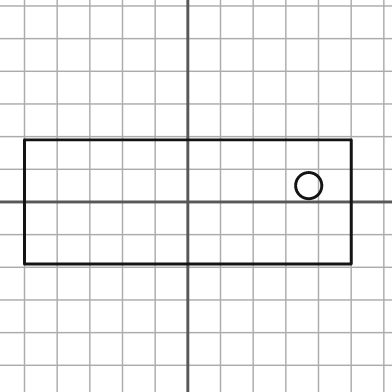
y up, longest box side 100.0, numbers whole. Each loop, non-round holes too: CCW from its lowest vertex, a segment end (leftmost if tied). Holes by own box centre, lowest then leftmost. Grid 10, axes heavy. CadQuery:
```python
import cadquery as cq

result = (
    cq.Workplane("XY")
    .moveTo(-50.0, -19.0)
    .lineTo(50.0, -19.0)
    .lineTo(50.0, 19.0)
    .lineTo(-50.0, 19.0)
    .close()
    .moveTo(37.0, 5.0)
    .circle(4.0)
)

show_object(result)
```